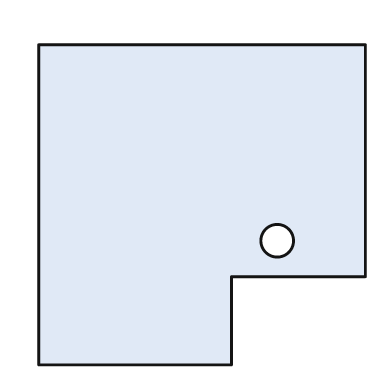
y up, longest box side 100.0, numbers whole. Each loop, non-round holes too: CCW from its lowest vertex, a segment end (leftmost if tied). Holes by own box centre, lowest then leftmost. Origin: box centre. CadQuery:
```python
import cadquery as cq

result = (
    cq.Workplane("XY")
    .moveTo(-50.0, -49.0)
    .lineTo(9.0, -49.0)
    .lineTo(9.0, -22.0)
    .lineTo(50.0, -22.0)
    .lineTo(50.0, 49.0)
    .lineTo(-50.0, 49.0)
    .close()
    .moveTo(23.0, -11.0)
    .circle(5.0)
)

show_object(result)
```